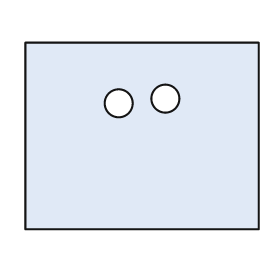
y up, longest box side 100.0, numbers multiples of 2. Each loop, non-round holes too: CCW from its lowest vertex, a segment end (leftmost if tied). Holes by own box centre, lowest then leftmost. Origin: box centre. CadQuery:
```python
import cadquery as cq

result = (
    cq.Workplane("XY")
    .moveTo(-50.0, -40.0)
    .lineTo(50.0, -40.0)
    .lineTo(50.0, 40.0)
    .lineTo(-50.0, 40.0)
    .close()
    .moveTo(-10.0, 14.0)
    .circle(6.0)
    .moveTo(10.0, 16.0)
    .circle(6.0)
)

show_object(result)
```